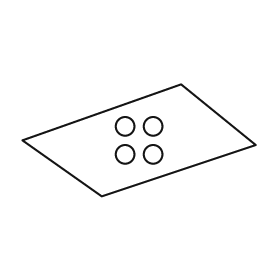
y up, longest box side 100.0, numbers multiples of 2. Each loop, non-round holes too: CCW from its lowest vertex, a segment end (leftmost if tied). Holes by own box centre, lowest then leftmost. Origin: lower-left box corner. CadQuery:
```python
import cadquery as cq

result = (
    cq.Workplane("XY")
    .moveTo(34.0, 0.0)
    .lineTo(100.0, 22.0)
    .lineTo(68.0, 48.0)
    .lineTo(0.0, 24.0)
    .close()
    .moveTo(44.0, 18.0)
    .circle(4.0)
    .moveTo(56.0, 18.0)
    .circle(4.0)
    .moveTo(44.0, 30.0)
    .circle(4.0)
    .moveTo(56.0, 30.0)
    .circle(4.0)
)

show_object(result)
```